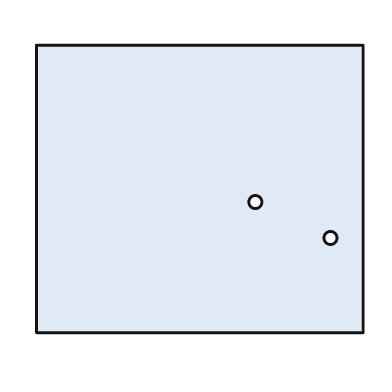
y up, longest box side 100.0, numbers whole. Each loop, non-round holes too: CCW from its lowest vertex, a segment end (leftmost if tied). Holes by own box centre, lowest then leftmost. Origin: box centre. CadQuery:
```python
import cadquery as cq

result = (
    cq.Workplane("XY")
    .moveTo(-50.0, -44.0)
    .lineTo(50.0, -44.0)
    .lineTo(50.0, 44.0)
    .lineTo(-50.0, 44.0)
    .close()
    .moveTo(40.0, -15.0)
    .circle(2.0)
    .moveTo(17.0, -4.0)
    .circle(2.0)
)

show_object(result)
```